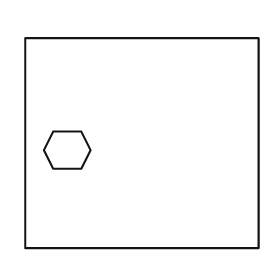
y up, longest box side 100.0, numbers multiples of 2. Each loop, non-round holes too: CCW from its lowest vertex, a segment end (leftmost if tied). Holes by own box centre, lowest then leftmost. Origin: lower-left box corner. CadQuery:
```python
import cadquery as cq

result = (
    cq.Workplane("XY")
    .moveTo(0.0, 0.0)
    .lineTo(100.0, 0.0)
    .lineTo(100.0, 90.0)
    .lineTo(0.0, 90.0)
    .close()
    .moveTo(12.0, 34.0)
    .lineTo(24.0, 34.0)
    .lineTo(28.0, 42.0)
    .lineTo(24.0, 50.0)
    .lineTo(12.0, 50.0)
    .lineTo(8.0, 42.0)
    .close()
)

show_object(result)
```